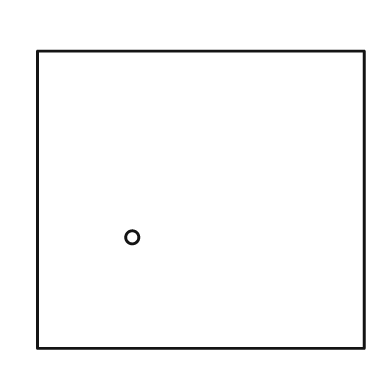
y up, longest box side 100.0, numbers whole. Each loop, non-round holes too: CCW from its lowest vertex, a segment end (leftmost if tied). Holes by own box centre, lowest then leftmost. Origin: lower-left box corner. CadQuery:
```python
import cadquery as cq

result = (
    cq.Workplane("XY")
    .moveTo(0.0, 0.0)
    .lineTo(100.0, 0.0)
    .lineTo(100.0, 91.0)
    .lineTo(0.0, 91.0)
    .close()
    .moveTo(29.0, 34.0)
    .circle(2.0)
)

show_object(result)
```